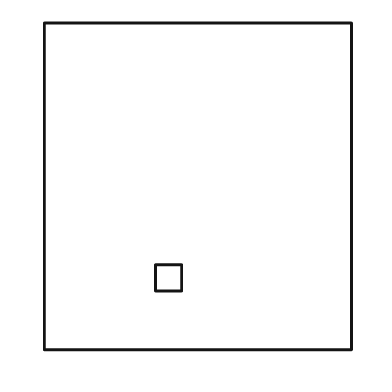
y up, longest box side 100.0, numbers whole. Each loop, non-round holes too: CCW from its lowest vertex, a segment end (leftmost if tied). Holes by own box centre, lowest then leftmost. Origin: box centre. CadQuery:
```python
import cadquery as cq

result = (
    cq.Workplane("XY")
    .moveTo(-47.0, -50.0)
    .lineTo(47.0, -50.0)
    .lineTo(47.0, 50.0)
    .lineTo(-47.0, 50.0)
    .close()
    .moveTo(-13.0, -32.0)
    .lineTo(-5.0, -32.0)
    .lineTo(-5.0, -24.0)
    .lineTo(-13.0, -24.0)
    .close()
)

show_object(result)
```